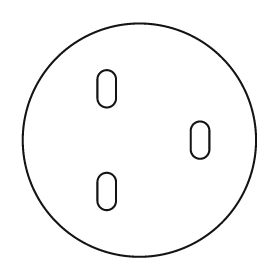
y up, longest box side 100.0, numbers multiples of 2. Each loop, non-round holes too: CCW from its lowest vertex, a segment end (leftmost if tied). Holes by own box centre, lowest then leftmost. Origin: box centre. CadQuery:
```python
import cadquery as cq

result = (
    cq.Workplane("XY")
    .moveTo(0.0, 0.0)
    .circle(50.0)
    .moveTo(-18.0, -26.0)
    .threePointArc((-14.0, -30.0), (-10.0, -26.0))
    .lineTo(-10.0, -18.0)
    .threePointArc((-14.0, -14.0), (-18.0, -18.0))
    .close()
    .moveTo(22.0, -4.0)
    .threePointArc((26.0, -8.0), (30.0, -4.0))
    .lineTo(30.0, 4.0)
    .threePointArc((26.0, 8.0), (22.0, 4.0))
    .close()
    .moveTo(-18.0, 18.0)
    .threePointArc((-14.0, 14.0), (-10.0, 18.0))
    .lineTo(-10.0, 26.0)
    .threePointArc((-14.0, 30.0), (-18.0, 26.0))
    .close()
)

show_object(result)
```